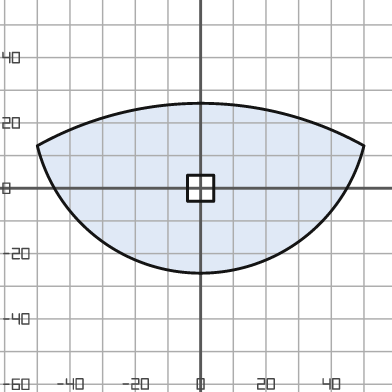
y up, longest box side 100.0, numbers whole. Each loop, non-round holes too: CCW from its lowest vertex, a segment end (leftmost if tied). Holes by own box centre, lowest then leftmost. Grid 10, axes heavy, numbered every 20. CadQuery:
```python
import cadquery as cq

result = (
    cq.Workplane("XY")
    .moveTo(-50.0, 13.0)
    .threePointArc((0.0, -26.0), (50.0, 13.0))
    .threePointArc((0.0, 26.0), (-50.0, 13.0))
    .close()
    .moveTo(-4.0, -4.0)
    .lineTo(4.0, -4.0)
    .lineTo(4.0, 4.0)
    .lineTo(-4.0, 4.0)
    .close()
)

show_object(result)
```